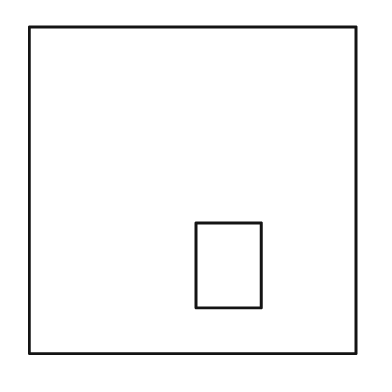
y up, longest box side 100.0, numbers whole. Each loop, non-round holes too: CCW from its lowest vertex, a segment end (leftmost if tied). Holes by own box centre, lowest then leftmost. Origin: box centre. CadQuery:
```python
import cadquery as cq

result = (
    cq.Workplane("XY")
    .moveTo(-50.0, -50.0)
    .lineTo(50.0, -50.0)
    .lineTo(50.0, 50.0)
    .lineTo(-50.0, 50.0)
    .close()
    .moveTo(1.0, -36.0)
    .lineTo(21.0, -36.0)
    .lineTo(21.0, -10.0)
    .lineTo(1.0, -10.0)
    .close()
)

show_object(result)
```